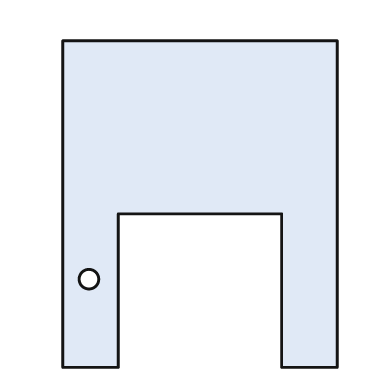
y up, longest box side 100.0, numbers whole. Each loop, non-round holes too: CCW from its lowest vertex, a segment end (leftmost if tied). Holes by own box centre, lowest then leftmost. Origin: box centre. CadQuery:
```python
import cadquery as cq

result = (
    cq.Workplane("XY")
    .moveTo(-42.0, -50.0)
    .lineTo(-25.0, -50.0)
    .lineTo(-25.0, -3.0)
    .lineTo(25.0, -3.0)
    .lineTo(25.0, -50.0)
    .lineTo(42.0, -50.0)
    .lineTo(42.0, 50.0)
    .lineTo(-42.0, 50.0)
    .close()
    .moveTo(-34.0, -23.0)
    .circle(3.0)
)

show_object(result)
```